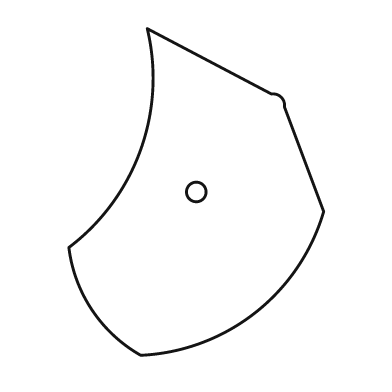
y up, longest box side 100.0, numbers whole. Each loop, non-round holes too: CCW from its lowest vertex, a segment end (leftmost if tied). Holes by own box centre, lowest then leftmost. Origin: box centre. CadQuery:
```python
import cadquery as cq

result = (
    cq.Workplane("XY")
    .moveTo(-17.0, -50.0)
    .threePointArc((18.0, -37.0), (39.0, -6.0))
    .lineTo(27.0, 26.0)
    .threePointArc((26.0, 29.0), (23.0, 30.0))
    .lineTo(-15.0, 50.0)
    .threePointArc((-17.0, 13.0), (-39.0, -17.0))
    .threePointArc((-32.0, -36.0), (-17.0, -50.0))
    .close()
    .moveTo(0.0, 0.0)
    .circle(3.0)
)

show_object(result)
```